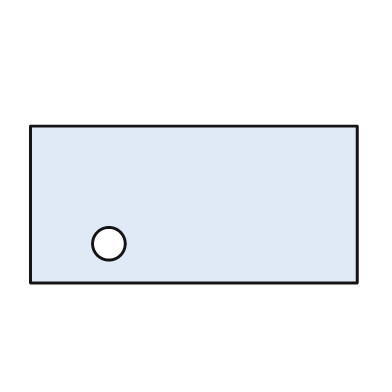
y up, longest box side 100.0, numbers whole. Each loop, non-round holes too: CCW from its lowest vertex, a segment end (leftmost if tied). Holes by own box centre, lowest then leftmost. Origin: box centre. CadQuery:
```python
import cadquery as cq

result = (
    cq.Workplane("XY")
    .moveTo(-50.0, -24.0)
    .lineTo(50.0, -24.0)
    .lineTo(50.0, 24.0)
    .lineTo(-50.0, 24.0)
    .close()
    .moveTo(-26.0, -12.0)
    .circle(5.0)
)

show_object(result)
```